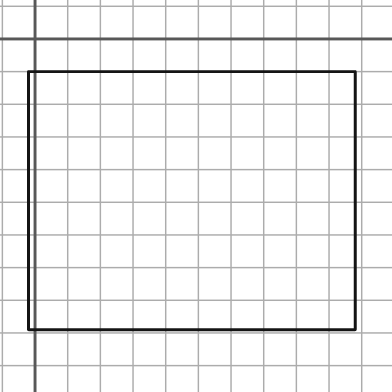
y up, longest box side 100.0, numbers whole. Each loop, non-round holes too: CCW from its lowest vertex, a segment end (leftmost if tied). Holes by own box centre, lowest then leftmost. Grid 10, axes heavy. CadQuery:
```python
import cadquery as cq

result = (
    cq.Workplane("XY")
    .moveTo(-2.0, -89.0)
    .lineTo(98.0, -89.0)
    .lineTo(98.0, -10.0)
    .lineTo(-2.0, -10.0)
    .close()
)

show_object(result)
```